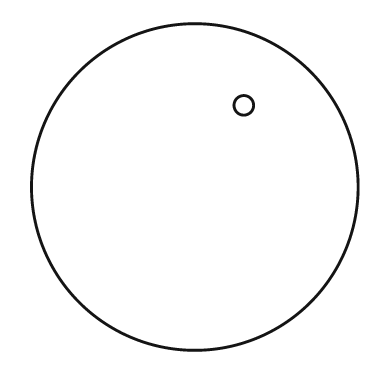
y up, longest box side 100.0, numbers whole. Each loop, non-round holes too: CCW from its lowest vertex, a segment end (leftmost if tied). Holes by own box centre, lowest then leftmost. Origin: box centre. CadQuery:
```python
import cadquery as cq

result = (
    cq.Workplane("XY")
    .moveTo(0.0, 0.0)
    .circle(50.0)
    .moveTo(15.0, 25.0)
    .circle(3.0)
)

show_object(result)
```